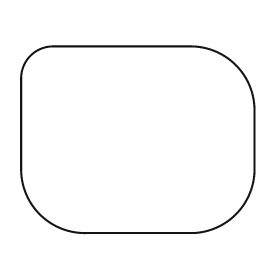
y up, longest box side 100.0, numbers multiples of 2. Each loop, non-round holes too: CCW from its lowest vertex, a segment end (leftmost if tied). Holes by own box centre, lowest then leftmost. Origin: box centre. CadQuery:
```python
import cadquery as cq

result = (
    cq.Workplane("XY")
    .moveTo(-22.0, -40.0)
    .lineTo(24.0, -40.0)
    .threePointArc((42.0, -32.0), (50.0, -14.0))
    .lineTo(50.0, 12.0)
    .threePointArc((42.0, 32.0), (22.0, 40.0))
    .lineTo(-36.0, 40.0)
    .threePointArc((-46.0, 36.0), (-50.0, 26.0))
    .lineTo(-50.0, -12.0)
    .threePointArc((-42.0, -32.0), (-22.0, -40.0))
    .close()
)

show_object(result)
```